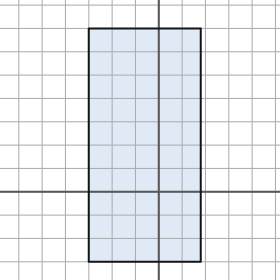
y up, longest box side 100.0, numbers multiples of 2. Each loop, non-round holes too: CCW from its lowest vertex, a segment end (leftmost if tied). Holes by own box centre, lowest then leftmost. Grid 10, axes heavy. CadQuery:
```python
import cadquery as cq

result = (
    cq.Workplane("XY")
    .moveTo(-30.0, -30.0)
    .lineTo(18.0, -30.0)
    .lineTo(18.0, 70.0)
    .lineTo(-30.0, 70.0)
    .close()
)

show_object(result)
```